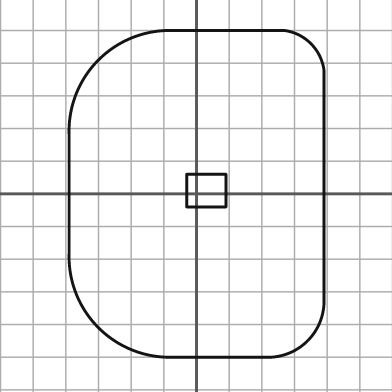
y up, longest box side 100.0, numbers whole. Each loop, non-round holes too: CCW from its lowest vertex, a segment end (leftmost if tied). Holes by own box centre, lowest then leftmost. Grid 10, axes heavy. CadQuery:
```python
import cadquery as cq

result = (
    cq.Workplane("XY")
    .moveTo(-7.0, -50.0)
    .lineTo(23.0, -50.0)
    .threePointArc((34.0, -45.0), (39.0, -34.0))
    .lineTo(39.0, 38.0)
    .threePointArc((35.0, 46.0), (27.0, 50.0))
    .lineTo(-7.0, 50.0)
    .threePointArc((-30.0, 41.0), (-39.0, 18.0))
    .lineTo(-39.0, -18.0)
    .threePointArc((-30.0, -41.0), (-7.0, -50.0))
    .close()
    .moveTo(-3.0, -4.0)
    .lineTo(9.0, -4.0)
    .lineTo(9.0, 6.0)
    .lineTo(-3.0, 6.0)
    .close()
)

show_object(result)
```